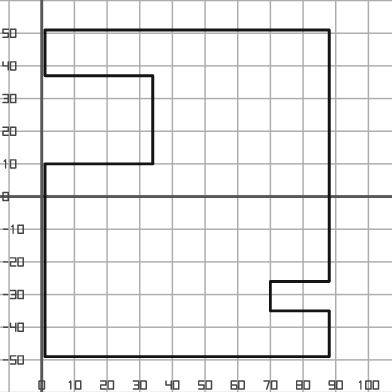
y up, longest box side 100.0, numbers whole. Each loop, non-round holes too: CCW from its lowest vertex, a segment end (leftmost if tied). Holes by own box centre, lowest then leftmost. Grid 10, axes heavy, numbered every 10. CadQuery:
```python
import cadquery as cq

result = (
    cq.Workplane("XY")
    .moveTo(1.0, -49.0)
    .lineTo(88.0, -49.0)
    .lineTo(88.0, -35.0)
    .lineTo(70.0, -35.0)
    .lineTo(70.0, -26.0)
    .lineTo(88.0, -26.0)
    .lineTo(88.0, 51.0)
    .lineTo(1.0, 51.0)
    .lineTo(1.0, 37.0)
    .lineTo(34.0, 37.0)
    .lineTo(34.0, 10.0)
    .lineTo(1.0, 10.0)
    .close()
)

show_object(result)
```